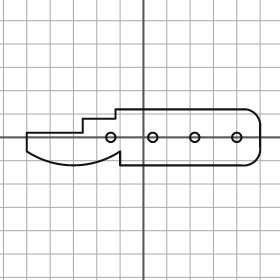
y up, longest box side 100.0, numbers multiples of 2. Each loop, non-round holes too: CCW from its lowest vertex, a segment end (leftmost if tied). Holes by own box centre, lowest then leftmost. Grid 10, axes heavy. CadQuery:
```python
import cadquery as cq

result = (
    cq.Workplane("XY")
    .moveTo(-10.0, -12.0)
    .lineTo(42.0, -12.0)
    .threePointArc((48.0, -10.0), (50.0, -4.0))
    .lineTo(50.0, 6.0)
    .threePointArc((48.0, 10.0), (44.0, 12.0))
    .lineTo(-12.0, 12.0)
    .lineTo(-12.0, 8.0)
    .lineTo(-26.0, 8.0)
    .lineTo(-26.0, 2.0)
    .lineTo(-50.0, 2.0)
    .lineTo(-50.0, -6.0)
    .threePointArc((-30.0, -12.0), (-10.0, -6.0))
    .close()
    .moveTo(-14.0, 0.0)
    .circle(2.0)
    .moveTo(4.0, 0.0)
    .circle(2.0)
    .moveTo(22.0, 0.0)
    .circle(2.0)
    .moveTo(40.0, 0.0)
    .circle(2.0)
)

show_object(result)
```